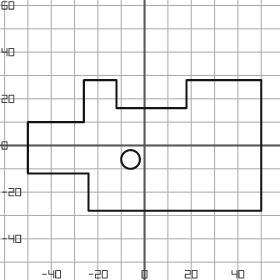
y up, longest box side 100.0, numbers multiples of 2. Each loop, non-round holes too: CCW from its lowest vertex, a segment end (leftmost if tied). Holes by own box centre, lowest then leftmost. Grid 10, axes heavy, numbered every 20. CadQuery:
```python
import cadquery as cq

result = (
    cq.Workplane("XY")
    .moveTo(-24.0, -28.0)
    .lineTo(50.0, -28.0)
    .lineTo(50.0, 28.0)
    .lineTo(18.0, 28.0)
    .lineTo(18.0, 16.0)
    .lineTo(-12.0, 16.0)
    .lineTo(-12.0, 28.0)
    .lineTo(-26.0, 28.0)
    .lineTo(-26.0, 10.0)
    .lineTo(-50.0, 10.0)
    .lineTo(-50.0, -12.0)
    .lineTo(-24.0, -12.0)
    .close()
    .moveTo(-6.0, -6.0)
    .circle(4.0)
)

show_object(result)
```